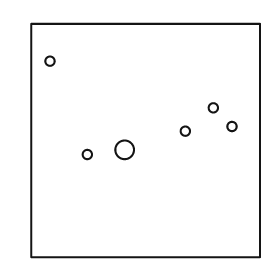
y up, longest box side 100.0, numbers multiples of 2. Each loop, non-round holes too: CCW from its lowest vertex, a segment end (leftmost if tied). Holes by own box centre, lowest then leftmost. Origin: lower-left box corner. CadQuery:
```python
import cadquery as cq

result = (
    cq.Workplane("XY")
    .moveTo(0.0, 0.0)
    .lineTo(98.0, 0.0)
    .lineTo(98.0, 100.0)
    .lineTo(0.0, 100.0)
    .close()
    .moveTo(24.0, 44.0)
    .circle(2.0)
    .moveTo(40.0, 46.0)
    .circle(4.0)
    .moveTo(66.0, 54.0)
    .circle(2.0)
    .moveTo(86.0, 56.0)
    .circle(2.0)
    .moveTo(78.0, 64.0)
    .circle(2.0)
    .moveTo(8.0, 84.0)
    .circle(2.0)
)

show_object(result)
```